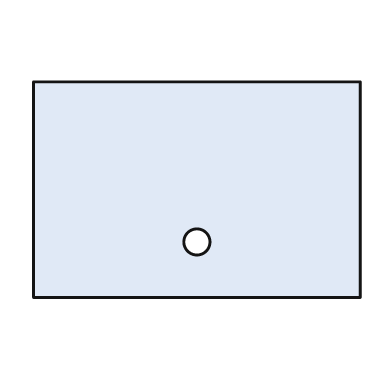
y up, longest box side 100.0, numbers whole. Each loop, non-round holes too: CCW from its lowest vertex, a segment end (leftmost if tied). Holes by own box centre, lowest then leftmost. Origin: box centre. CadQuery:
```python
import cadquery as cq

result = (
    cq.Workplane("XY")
    .moveTo(-50.0, -33.0)
    .lineTo(50.0, -33.0)
    .lineTo(50.0, 33.0)
    .lineTo(-50.0, 33.0)
    .close()
    .moveTo(0.0, -16.0)
    .circle(4.0)
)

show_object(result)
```